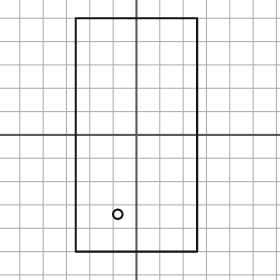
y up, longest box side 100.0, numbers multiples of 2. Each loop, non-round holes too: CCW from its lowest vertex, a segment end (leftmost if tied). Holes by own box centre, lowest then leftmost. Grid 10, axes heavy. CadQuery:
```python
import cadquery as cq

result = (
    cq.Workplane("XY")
    .moveTo(-26.0, -50.0)
    .lineTo(26.0, -50.0)
    .lineTo(26.0, 50.0)
    .lineTo(-26.0, 50.0)
    .close()
    .moveTo(-8.0, -34.0)
    .circle(2.0)
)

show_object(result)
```